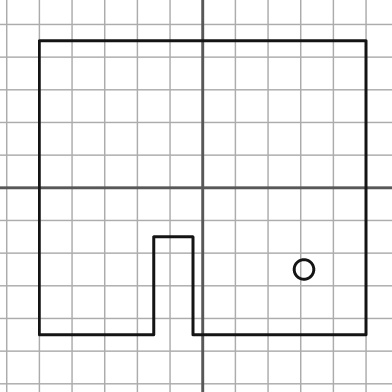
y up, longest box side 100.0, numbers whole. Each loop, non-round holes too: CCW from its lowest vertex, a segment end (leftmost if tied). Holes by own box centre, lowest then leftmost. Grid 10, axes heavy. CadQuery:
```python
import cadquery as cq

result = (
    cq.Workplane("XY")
    .moveTo(-50.0, -45.0)
    .lineTo(-15.0, -45.0)
    .lineTo(-15.0, -15.0)
    .lineTo(-3.0, -15.0)
    .lineTo(-3.0, -45.0)
    .lineTo(50.0, -45.0)
    .lineTo(50.0, 45.0)
    .lineTo(-50.0, 45.0)
    .close()
    .moveTo(31.0, -25.0)
    .circle(3.0)
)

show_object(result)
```